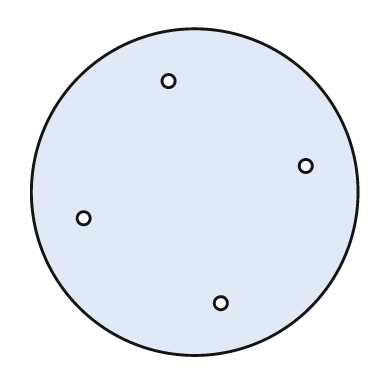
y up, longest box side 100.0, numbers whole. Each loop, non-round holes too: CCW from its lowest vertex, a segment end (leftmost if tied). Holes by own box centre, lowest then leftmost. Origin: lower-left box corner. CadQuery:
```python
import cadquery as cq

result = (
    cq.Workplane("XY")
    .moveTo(50.0, 50.0)
    .circle(50.0)
    .moveTo(58.0, 16.0)
    .circle(2.0)
    .moveTo(16.0, 42.0)
    .circle(2.0)
    .moveTo(84.0, 58.0)
    .circle(2.0)
    .moveTo(42.0, 84.0)
    .circle(2.0)
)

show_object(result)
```